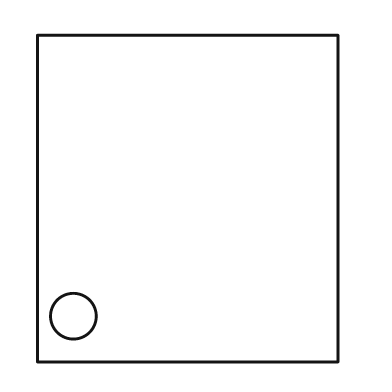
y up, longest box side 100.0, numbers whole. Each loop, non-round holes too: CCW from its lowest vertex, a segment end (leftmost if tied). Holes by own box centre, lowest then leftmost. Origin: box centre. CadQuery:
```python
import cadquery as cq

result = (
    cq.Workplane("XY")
    .moveTo(-46.0, -50.0)
    .lineTo(46.0, -50.0)
    .lineTo(46.0, 50.0)
    .lineTo(-46.0, 50.0)
    .close()
    .moveTo(-35.0, -36.0)
    .circle(7.0)
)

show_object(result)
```